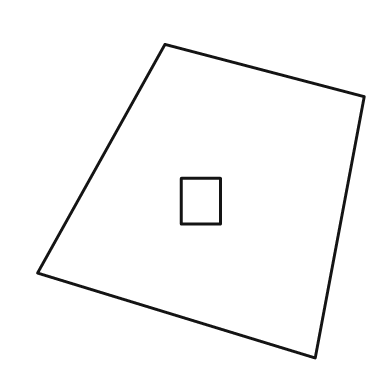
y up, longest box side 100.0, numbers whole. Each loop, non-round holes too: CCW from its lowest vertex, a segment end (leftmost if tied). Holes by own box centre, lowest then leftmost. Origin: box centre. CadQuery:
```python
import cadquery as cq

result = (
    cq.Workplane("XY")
    .moveTo(35.0, -48.0)
    .lineTo(50.0, 32.0)
    .lineTo(-11.0, 48.0)
    .lineTo(-50.0, -22.0)
    .close()
    .moveTo(-6.0, -7.0)
    .lineTo(6.0, -7.0)
    .lineTo(6.0, 7.0)
    .lineTo(-6.0, 7.0)
    .close()
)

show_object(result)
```